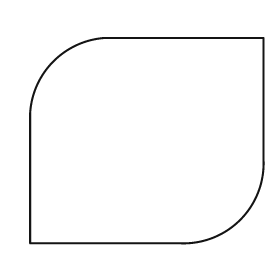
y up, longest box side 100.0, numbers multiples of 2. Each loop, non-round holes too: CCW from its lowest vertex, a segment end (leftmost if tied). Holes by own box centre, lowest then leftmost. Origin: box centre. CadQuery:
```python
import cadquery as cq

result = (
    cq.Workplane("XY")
    .moveTo(-50.0, -44.0)
    .lineTo(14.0, -44.0)
    .threePointArc((40.0, -34.0), (50.0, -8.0))
    .lineTo(50.0, 44.0)
    .lineTo(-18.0, 44.0)
    .threePointArc((-40.0, 34.0), (-50.0, 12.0))
    .close()
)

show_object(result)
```